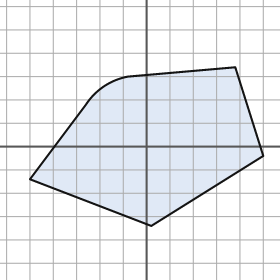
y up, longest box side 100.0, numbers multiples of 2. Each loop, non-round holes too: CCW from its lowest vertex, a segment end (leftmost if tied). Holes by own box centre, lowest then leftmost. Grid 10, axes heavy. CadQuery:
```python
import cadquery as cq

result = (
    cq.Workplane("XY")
    .moveTo(2.0, -34.0)
    .lineTo(50.0, -4.0)
    .lineTo(38.0, 34.0)
    .lineTo(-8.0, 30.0)
    .threePointArc((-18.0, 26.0), (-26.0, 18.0))
    .lineTo(-50.0, -14.0)
    .close()
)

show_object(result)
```